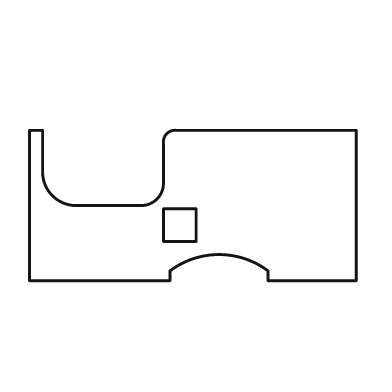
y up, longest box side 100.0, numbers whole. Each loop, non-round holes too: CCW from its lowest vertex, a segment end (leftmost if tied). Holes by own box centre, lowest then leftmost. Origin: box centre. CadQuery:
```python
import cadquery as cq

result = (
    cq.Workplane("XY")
    .moveTo(-50.0, -23.0)
    .lineTo(-7.0, -23.0)
    .lineTo(-7.0, -20.0)
    .threePointArc((8.0, -15.0), (23.0, -20.0))
    .lineTo(23.0, -23.0)
    .lineTo(50.0, -23.0)
    .lineTo(50.0, 23.0)
    .lineTo(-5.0, 23.0)
    .threePointArc((-8.0, 22.0), (-9.0, 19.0))
    .lineTo(-9.0, 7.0)
    .threePointArc((-11.0, 2.0), (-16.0, 0.0))
    .lineTo(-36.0, 0.0)
    .threePointArc((-43.0, 3.0), (-46.0, 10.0))
    .lineTo(-46.0, 23.0)
    .lineTo(-50.0, 23.0)
    .close()
    .moveTo(-9.0, -11.0)
    .lineTo(1.0, -11.0)
    .lineTo(1.0, -1.0)
    .lineTo(-9.0, -1.0)
    .close()
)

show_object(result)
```